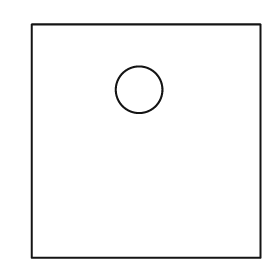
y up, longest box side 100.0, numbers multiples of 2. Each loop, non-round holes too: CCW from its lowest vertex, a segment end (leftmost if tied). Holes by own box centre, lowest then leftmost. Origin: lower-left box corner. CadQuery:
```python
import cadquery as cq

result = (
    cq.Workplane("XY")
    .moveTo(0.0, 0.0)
    .lineTo(98.0, 0.0)
    .lineTo(98.0, 100.0)
    .lineTo(0.0, 100.0)
    .close()
    .moveTo(46.0, 72.0)
    .circle(10.0)
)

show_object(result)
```